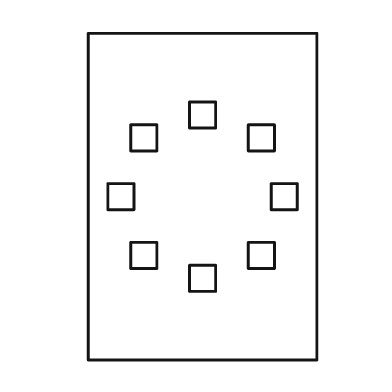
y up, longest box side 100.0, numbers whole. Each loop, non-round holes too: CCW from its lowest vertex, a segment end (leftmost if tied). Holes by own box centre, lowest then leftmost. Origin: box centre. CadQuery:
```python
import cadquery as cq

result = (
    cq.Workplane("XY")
    .moveTo(-35.0, -50.0)
    .lineTo(35.0, -50.0)
    .lineTo(35.0, 50.0)
    .lineTo(-35.0, 50.0)
    .close()
    .moveTo(-4.0, -29.0)
    .lineTo(4.0, -29.0)
    .lineTo(4.0, -21.0)
    .lineTo(-4.0, -21.0)
    .close()
    .moveTo(-22.0, -22.0)
    .lineTo(-14.0, -22.0)
    .lineTo(-14.0, -14.0)
    .lineTo(-22.0, -14.0)
    .close()
    .moveTo(14.0, -22.0)
    .lineTo(22.0, -22.0)
    .lineTo(22.0, -14.0)
    .lineTo(14.0, -14.0)
    .close()
    .moveTo(-29.0, -4.0)
    .lineTo(-21.0, -4.0)
    .lineTo(-21.0, 4.0)
    .lineTo(-29.0, 4.0)
    .close()
    .moveTo(21.0, -4.0)
    .lineTo(29.0, -4.0)
    .lineTo(29.0, 4.0)
    .lineTo(21.0, 4.0)
    .close()
    .moveTo(-22.0, 14.0)
    .lineTo(-14.0, 14.0)
    .lineTo(-14.0, 22.0)
    .lineTo(-22.0, 22.0)
    .close()
    .moveTo(14.0, 14.0)
    .lineTo(22.0, 14.0)
    .lineTo(22.0, 22.0)
    .lineTo(14.0, 22.0)
    .close()
    .moveTo(-4.0, 21.0)
    .lineTo(4.0, 21.0)
    .lineTo(4.0, 29.0)
    .lineTo(-4.0, 29.0)
    .close()
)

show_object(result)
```